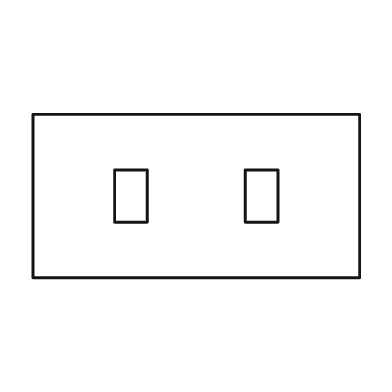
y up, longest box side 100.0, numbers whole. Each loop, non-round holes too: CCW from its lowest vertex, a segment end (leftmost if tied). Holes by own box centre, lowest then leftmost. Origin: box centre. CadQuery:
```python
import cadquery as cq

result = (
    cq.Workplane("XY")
    .moveTo(-50.0, -25.0)
    .lineTo(50.0, -25.0)
    .lineTo(50.0, 25.0)
    .lineTo(-50.0, 25.0)
    .close()
    .moveTo(-25.0, -8.0)
    .lineTo(-15.0, -8.0)
    .lineTo(-15.0, 8.0)
    .lineTo(-25.0, 8.0)
    .close()
    .moveTo(15.0, -8.0)
    .lineTo(25.0, -8.0)
    .lineTo(25.0, 8.0)
    .lineTo(15.0, 8.0)
    .close()
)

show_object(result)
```